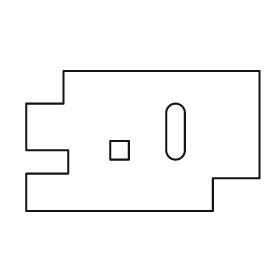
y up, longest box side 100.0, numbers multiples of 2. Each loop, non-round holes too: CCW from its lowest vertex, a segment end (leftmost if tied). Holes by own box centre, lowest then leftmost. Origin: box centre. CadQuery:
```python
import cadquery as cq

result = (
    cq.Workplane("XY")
    .moveTo(-50.0, -30.0)
    .lineTo(30.0, -30.0)
    .lineTo(30.0, -16.0)
    .lineTo(50.0, -16.0)
    .lineTo(50.0, 30.0)
    .lineTo(-34.0, 30.0)
    .lineTo(-34.0, 16.0)
    .lineTo(-50.0, 16.0)
    .lineTo(-50.0, -4.0)
    .lineTo(-32.0, -4.0)
    .lineTo(-32.0, -14.0)
    .lineTo(-50.0, -14.0)
    .close()
    .moveTo(-14.0, -8.0)
    .lineTo(-6.0, -8.0)
    .lineTo(-6.0, 0.0)
    .lineTo(-14.0, 0.0)
    .close()
    .moveTo(10.0, -4.0)
    .threePointArc((14.0, -8.0), (18.0, -4.0))
    .lineTo(18.0, 12.0)
    .threePointArc((14.0, 16.0), (10.0, 12.0))
    .close()
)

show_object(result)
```